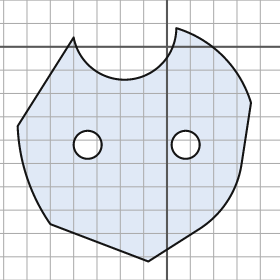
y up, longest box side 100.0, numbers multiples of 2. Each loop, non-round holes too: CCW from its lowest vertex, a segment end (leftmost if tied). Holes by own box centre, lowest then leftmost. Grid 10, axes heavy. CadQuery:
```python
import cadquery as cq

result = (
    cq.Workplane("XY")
    .moveTo(-8.0, -92.0)
    .lineTo(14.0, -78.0)
    .threePointArc((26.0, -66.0), (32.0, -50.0))
    .lineTo(36.0, -24.0)
    .threePointArc((24.0, -4.0), (4.0, 8.0))
    .threePointArc((-16.0, -14.0), (-40.0, 4.0))
    .lineTo(-64.0, -34.0)
    .threePointArc((-60.0, -56.0), (-50.0, -76.0))
    .close()
    .moveTo(-34.0, -42.0)
    .circle(6.0)
    .moveTo(8.0, -42.0)
    .circle(6.0)
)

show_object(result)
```